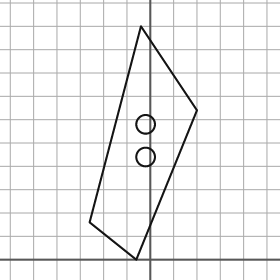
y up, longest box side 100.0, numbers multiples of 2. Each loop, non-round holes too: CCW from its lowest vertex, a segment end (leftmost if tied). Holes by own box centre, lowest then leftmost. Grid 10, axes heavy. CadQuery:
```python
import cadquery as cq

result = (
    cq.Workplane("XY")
    .moveTo(-6.0, 0.0)
    .lineTo(20.0, 64.0)
    .lineTo(-4.0, 100.0)
    .lineTo(-26.0, 16.0)
    .close()
    .moveTo(-2.0, 44.0)
    .circle(4.0)
    .moveTo(-2.0, 58.0)
    .circle(4.0)
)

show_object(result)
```